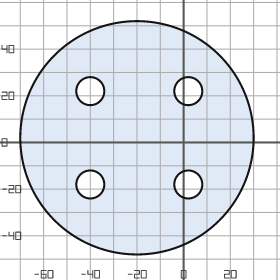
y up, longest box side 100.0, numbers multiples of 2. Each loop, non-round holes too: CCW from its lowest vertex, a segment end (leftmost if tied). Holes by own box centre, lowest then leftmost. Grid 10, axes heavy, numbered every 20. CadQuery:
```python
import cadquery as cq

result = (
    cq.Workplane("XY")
    .moveTo(-20.0, 2.0)
    .circle(50.0)
    .moveTo(-40.0, -18.0)
    .circle(6.0)
    .moveTo(2.0, -18.0)
    .circle(6.0)
    .moveTo(-40.0, 22.0)
    .circle(6.0)
    .moveTo(2.0, 22.0)
    .circle(6.0)
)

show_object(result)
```